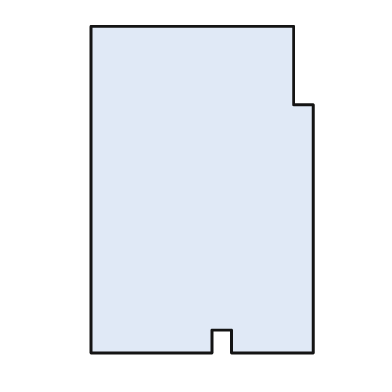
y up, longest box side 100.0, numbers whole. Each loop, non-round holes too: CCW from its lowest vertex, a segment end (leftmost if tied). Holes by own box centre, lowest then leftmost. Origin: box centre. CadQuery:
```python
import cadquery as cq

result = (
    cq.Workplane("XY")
    .moveTo(-34.0, -50.0)
    .lineTo(3.0, -50.0)
    .lineTo(3.0, -43.0)
    .lineTo(9.0, -43.0)
    .lineTo(9.0, -50.0)
    .lineTo(34.0, -50.0)
    .lineTo(34.0, 26.0)
    .lineTo(28.0, 26.0)
    .lineTo(28.0, 50.0)
    .lineTo(-34.0, 50.0)
    .close()
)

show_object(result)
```